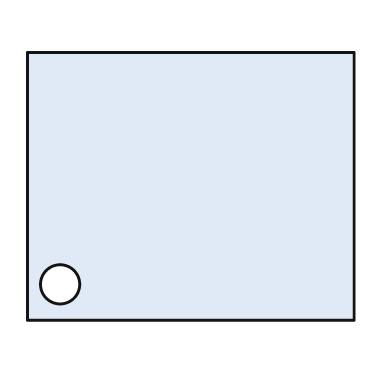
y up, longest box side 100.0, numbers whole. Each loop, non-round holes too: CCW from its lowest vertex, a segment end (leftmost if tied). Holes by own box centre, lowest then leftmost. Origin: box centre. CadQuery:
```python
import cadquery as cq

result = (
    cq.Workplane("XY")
    .moveTo(-50.0, -41.0)
    .lineTo(50.0, -41.0)
    .lineTo(50.0, 41.0)
    .lineTo(-50.0, 41.0)
    .close()
    .moveTo(-40.0, -30.0)
    .circle(6.0)
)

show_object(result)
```